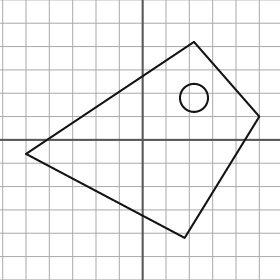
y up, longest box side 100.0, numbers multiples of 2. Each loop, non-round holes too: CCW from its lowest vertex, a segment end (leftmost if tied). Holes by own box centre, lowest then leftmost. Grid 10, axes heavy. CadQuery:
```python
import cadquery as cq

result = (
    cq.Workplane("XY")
    .moveTo(18.0, -42.0)
    .lineTo(50.0, 10.0)
    .lineTo(22.0, 42.0)
    .lineTo(-50.0, -6.0)
    .close()
    .moveTo(22.0, 18.0)
    .circle(6.0)
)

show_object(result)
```